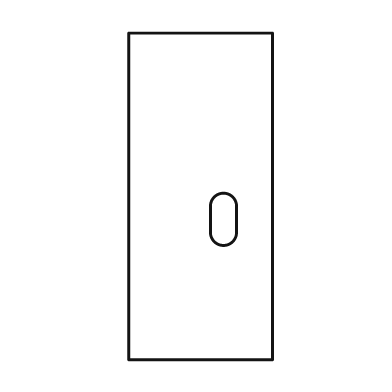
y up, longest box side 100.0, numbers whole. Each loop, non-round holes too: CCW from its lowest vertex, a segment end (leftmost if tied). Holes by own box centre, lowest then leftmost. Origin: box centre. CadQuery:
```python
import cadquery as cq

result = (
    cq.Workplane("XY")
    .moveTo(-22.0, -50.0)
    .lineTo(22.0, -50.0)
    .lineTo(22.0, 50.0)
    .lineTo(-22.0, 50.0)
    .close()
    .moveTo(3.0, -11.0)
    .threePointArc((7.0, -15.0), (11.0, -11.0))
    .lineTo(11.0, -3.0)
    .threePointArc((7.0, 1.0), (3.0, -3.0))
    .close()
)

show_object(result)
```